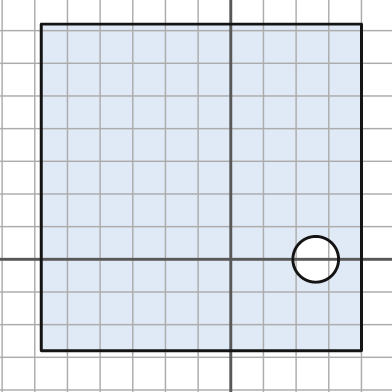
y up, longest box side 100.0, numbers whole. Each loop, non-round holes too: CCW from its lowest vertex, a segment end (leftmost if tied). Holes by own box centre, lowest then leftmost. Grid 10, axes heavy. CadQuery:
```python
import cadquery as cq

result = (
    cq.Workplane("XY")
    .moveTo(-58.0, -28.0)
    .lineTo(40.0, -28.0)
    .lineTo(40.0, 72.0)
    .lineTo(-58.0, 72.0)
    .close()
    .moveTo(26.0, 0.0)
    .circle(7.0)
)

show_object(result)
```